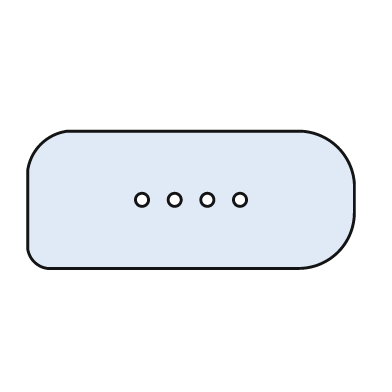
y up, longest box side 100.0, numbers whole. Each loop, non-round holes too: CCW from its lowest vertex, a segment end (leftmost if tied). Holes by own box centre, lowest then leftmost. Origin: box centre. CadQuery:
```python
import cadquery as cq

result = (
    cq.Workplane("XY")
    .moveTo(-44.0, -21.0)
    .lineTo(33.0, -21.0)
    .threePointArc((45.0, -16.0), (50.0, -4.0))
    .lineTo(50.0, 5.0)
    .threePointArc((45.0, 16.0), (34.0, 21.0))
    .lineTo(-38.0, 21.0)
    .threePointArc((-46.0, 17.0), (-50.0, 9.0))
    .lineTo(-50.0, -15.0)
    .threePointArc((-48.0, -19.0), (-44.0, -21.0))
    .close()
    .moveTo(-15.0, 0.0)
    .circle(2.0)
    .moveTo(-5.0, 0.0)
    .circle(2.0)
    .moveTo(5.0, 0.0)
    .circle(2.0)
    .moveTo(15.0, 0.0)
    .circle(2.0)
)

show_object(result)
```